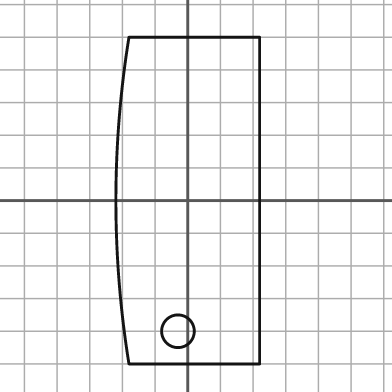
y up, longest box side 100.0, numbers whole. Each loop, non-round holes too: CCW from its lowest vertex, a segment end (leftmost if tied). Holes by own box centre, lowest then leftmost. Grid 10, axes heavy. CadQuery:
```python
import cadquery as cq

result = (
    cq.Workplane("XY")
    .moveTo(-18.0, -50.0)
    .lineTo(22.0, -50.0)
    .lineTo(22.0, 50.0)
    .lineTo(-18.0, 50.0)
    .threePointArc((-22.0, 0.0), (-18.0, -50.0))
    .close()
    .moveTo(-3.0, -40.0)
    .circle(5.0)
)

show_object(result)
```